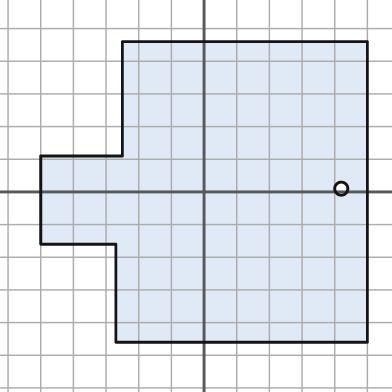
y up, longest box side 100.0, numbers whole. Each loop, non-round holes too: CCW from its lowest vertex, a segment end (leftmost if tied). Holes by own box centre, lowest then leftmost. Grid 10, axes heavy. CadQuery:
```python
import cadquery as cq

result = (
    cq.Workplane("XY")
    .moveTo(-27.0, -46.0)
    .lineTo(50.0, -46.0)
    .lineTo(50.0, 46.0)
    .lineTo(-25.0, 46.0)
    .lineTo(-25.0, 11.0)
    .lineTo(-50.0, 11.0)
    .lineTo(-50.0, -16.0)
    .lineTo(-27.0, -16.0)
    .close()
    .moveTo(42.0, 1.0)
    .circle(2.0)
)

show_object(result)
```